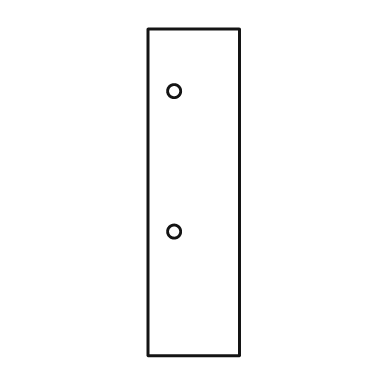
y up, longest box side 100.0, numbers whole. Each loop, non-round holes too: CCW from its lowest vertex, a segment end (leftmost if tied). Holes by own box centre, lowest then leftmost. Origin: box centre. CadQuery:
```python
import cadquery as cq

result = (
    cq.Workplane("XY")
    .moveTo(-14.0, -50.0)
    .lineTo(14.0, -50.0)
    .lineTo(14.0, 50.0)
    .lineTo(-14.0, 50.0)
    .close()
    .moveTo(-6.0, -12.0)
    .circle(2.0)
    .moveTo(-6.0, 31.0)
    .circle(2.0)
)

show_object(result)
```